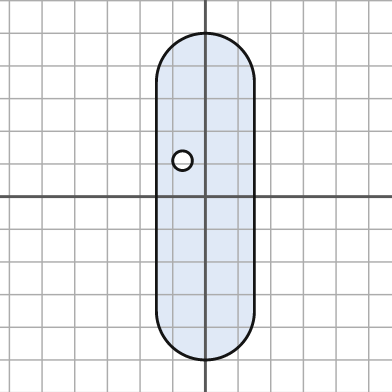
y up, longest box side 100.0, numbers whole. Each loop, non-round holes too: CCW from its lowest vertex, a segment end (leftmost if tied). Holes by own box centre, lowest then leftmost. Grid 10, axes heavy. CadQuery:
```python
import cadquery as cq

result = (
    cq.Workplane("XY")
    .moveTo(-15.0, -35.0)
    .threePointArc((0.0, -50.0), (15.0, -35.0))
    .lineTo(15.0, 35.0)
    .threePointArc((0.0, 50.0), (-15.0, 35.0))
    .close()
    .moveTo(-7.0, 11.0)
    .circle(3.0)
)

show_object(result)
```